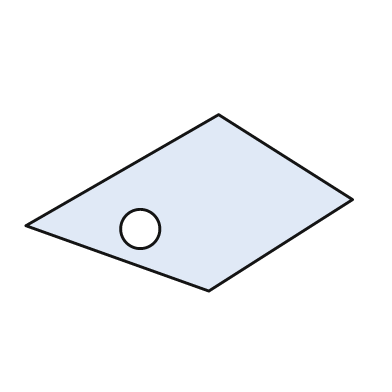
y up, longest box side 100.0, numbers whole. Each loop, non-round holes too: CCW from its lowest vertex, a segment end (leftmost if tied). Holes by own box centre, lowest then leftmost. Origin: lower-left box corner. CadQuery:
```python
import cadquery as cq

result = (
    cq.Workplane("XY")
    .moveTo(56.0, 0.0)
    .lineTo(100.0, 28.0)
    .lineTo(59.0, 54.0)
    .lineTo(0.0, 20.0)
    .close()
    .moveTo(35.0, 19.0)
    .circle(6.0)
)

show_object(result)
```